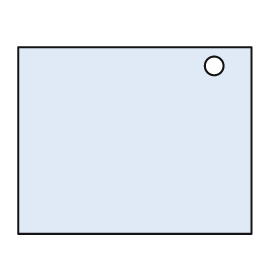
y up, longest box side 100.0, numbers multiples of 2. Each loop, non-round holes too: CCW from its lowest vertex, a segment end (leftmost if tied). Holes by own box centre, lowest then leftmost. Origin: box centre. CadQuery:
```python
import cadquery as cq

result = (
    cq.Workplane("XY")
    .moveTo(-50.0, -40.0)
    .lineTo(50.0, -40.0)
    .lineTo(50.0, 40.0)
    .lineTo(-50.0, 40.0)
    .close()
    .moveTo(34.0, 32.0)
    .circle(4.0)
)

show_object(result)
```